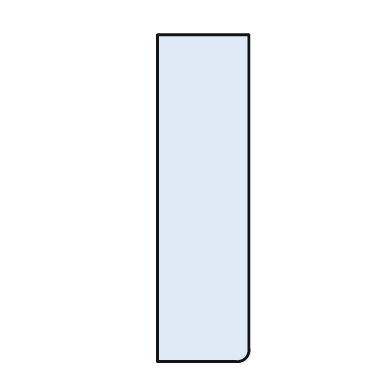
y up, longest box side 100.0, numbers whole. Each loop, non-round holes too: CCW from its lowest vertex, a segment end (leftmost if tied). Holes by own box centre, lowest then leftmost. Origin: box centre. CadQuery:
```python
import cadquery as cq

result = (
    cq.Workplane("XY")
    .moveTo(-14.0, -50.0)
    .lineTo(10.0, -50.0)
    .threePointArc((13.0, -49.0), (14.0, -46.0))
    .lineTo(14.0, 50.0)
    .lineTo(-14.0, 50.0)
    .close()
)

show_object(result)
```